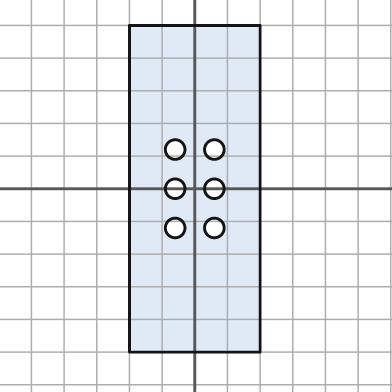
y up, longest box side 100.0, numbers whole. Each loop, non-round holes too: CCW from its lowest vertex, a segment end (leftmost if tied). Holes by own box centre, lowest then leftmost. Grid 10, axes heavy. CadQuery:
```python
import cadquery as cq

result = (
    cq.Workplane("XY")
    .moveTo(-20.0, -50.0)
    .lineTo(20.0, -50.0)
    .lineTo(20.0, 50.0)
    .lineTo(-20.0, 50.0)
    .close()
    .moveTo(-6.0, -12.0)
    .circle(3.0)
    .moveTo(6.0, -12.0)
    .circle(3.0)
    .moveTo(-6.0, 0.0)
    .circle(3.0)
    .moveTo(6.0, 0.0)
    .circle(3.0)
    .moveTo(-6.0, 12.0)
    .circle(3.0)
    .moveTo(6.0, 12.0)
    .circle(3.0)
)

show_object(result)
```